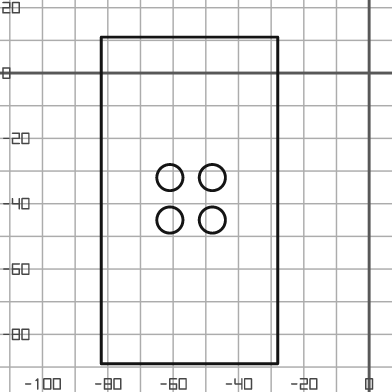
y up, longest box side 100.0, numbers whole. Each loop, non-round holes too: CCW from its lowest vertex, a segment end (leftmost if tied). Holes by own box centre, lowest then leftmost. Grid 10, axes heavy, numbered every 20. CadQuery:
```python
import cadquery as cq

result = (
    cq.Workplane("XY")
    .moveTo(-82.0, -89.0)
    .lineTo(-28.0, -89.0)
    .lineTo(-28.0, 11.0)
    .lineTo(-82.0, 11.0)
    .close()
    .moveTo(-61.0, -45.0)
    .circle(4.0)
    .moveTo(-48.0, -45.0)
    .circle(4.0)
    .moveTo(-61.0, -32.0)
    .circle(4.0)
    .moveTo(-48.0, -32.0)
    .circle(4.0)
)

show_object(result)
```